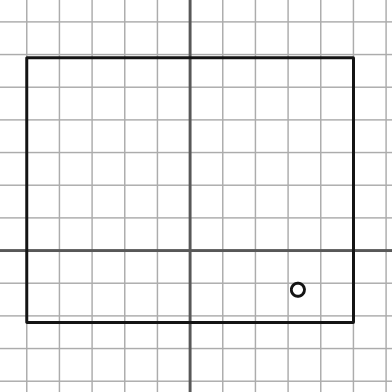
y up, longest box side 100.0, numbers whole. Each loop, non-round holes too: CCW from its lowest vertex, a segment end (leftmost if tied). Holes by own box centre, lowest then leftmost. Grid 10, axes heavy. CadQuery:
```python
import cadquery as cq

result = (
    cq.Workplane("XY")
    .moveTo(-50.0, -22.0)
    .lineTo(50.0, -22.0)
    .lineTo(50.0, 59.0)
    .lineTo(-50.0, 59.0)
    .close()
    .moveTo(33.0, -12.0)
    .circle(2.0)
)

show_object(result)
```